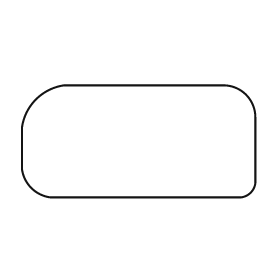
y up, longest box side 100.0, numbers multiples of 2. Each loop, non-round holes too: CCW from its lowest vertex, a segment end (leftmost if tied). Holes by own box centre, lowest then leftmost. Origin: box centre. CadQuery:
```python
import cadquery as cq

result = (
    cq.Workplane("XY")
    .moveTo(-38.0, -24.0)
    .lineTo(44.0, -24.0)
    .threePointArc((48.0, -22.0), (50.0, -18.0))
    .lineTo(50.0, 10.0)
    .threePointArc((46.0, 20.0), (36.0, 24.0))
    .lineTo(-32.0, 24.0)
    .threePointArc((-44.0, 18.0), (-50.0, 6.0))
    .lineTo(-50.0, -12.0)
    .threePointArc((-46.0, -20.0), (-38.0, -24.0))
    .close()
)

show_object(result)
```